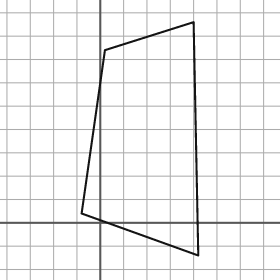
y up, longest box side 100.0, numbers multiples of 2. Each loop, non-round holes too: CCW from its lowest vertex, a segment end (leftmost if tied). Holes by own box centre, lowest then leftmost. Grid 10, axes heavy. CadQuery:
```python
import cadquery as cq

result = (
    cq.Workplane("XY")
    .moveTo(42.0, -14.0)
    .lineTo(40.0, 86.0)
    .lineTo(2.0, 74.0)
    .lineTo(-8.0, 4.0)
    .close()
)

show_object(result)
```